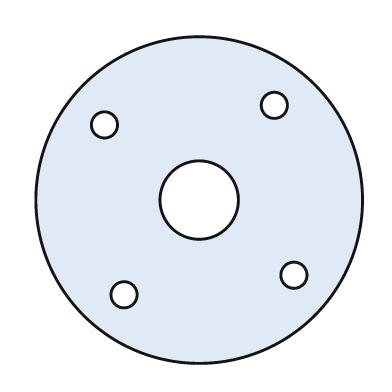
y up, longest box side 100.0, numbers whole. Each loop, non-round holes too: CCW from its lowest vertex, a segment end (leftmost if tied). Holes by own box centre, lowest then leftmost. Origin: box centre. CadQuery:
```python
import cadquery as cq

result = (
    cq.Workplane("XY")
    .moveTo(0.0, 0.0)
    .circle(50.0)
    .moveTo(-23.0, -29.0)
    .circle(4.0)
    .moveTo(29.0, -23.0)
    .circle(4.0)
    .moveTo(0.0, 0.0)
    .circle(12.0)
    .moveTo(-29.0, 23.0)
    .circle(4.0)
    .moveTo(23.0, 29.0)
    .circle(4.0)
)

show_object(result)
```